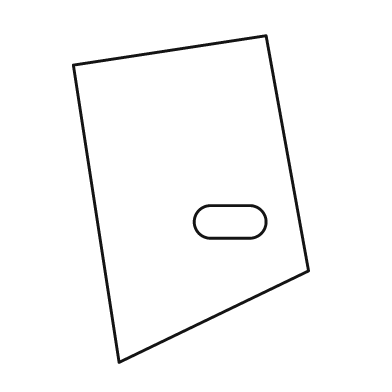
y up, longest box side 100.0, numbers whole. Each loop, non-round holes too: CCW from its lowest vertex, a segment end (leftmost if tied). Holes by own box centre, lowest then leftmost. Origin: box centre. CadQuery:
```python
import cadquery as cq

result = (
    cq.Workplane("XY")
    .moveTo(-22.0, -50.0)
    .lineTo(36.0, -22.0)
    .lineTo(23.0, 50.0)
    .lineTo(-36.0, 41.0)
    .close()
    .moveTo(6.0, -12.0)
    .lineTo(18.0, -12.0)
    .threePointArc((23.0, -7.0), (18.0, -2.0))
    .lineTo(6.0, -2.0)
    .threePointArc((1.0, -7.0), (6.0, -12.0))
    .close()
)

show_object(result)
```